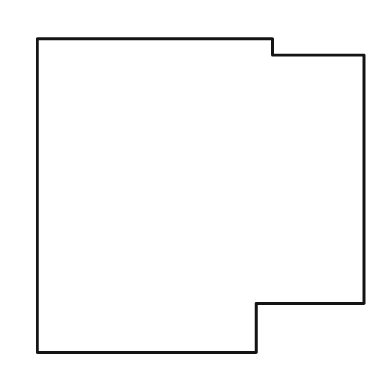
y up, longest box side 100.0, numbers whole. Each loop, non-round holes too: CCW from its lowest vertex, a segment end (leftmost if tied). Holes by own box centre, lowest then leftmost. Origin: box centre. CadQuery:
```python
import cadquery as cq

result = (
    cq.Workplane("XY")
    .moveTo(-50.0, -48.0)
    .lineTo(17.0, -48.0)
    .lineTo(17.0, -33.0)
    .lineTo(50.0, -33.0)
    .lineTo(50.0, 43.0)
    .lineTo(22.0, 43.0)
    .lineTo(22.0, 48.0)
    .lineTo(-50.0, 48.0)
    .close()
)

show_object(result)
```